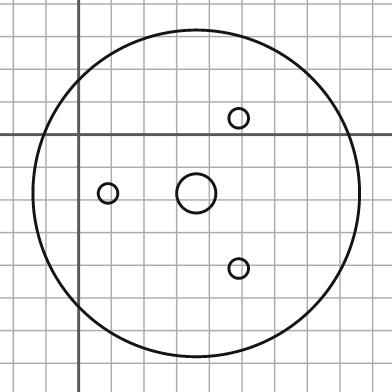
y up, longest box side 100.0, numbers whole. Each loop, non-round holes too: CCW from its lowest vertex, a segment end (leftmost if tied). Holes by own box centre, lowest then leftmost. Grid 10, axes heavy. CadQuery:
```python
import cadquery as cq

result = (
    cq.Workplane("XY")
    .moveTo(36.0, -18.0)
    .circle(50.0)
    .moveTo(49.0, -41.0)
    .circle(3.0)
    .moveTo(9.0, -18.0)
    .circle(3.0)
    .moveTo(36.0, -18.0)
    .circle(6.0)
    .moveTo(49.0, 5.0)
    .circle(3.0)
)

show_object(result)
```